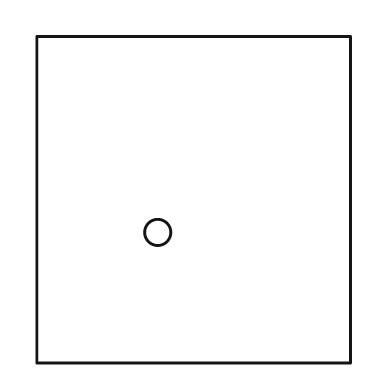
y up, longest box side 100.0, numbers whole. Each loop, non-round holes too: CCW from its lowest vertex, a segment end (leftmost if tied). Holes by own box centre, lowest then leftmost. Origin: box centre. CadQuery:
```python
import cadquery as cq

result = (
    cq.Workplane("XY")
    .moveTo(-48.0, -50.0)
    .lineTo(48.0, -50.0)
    .lineTo(48.0, 50.0)
    .lineTo(-48.0, 50.0)
    .close()
    .moveTo(-11.0, -10.0)
    .circle(4.0)
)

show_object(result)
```